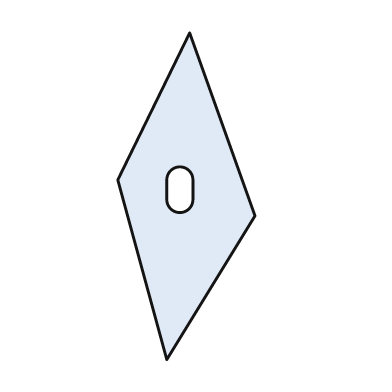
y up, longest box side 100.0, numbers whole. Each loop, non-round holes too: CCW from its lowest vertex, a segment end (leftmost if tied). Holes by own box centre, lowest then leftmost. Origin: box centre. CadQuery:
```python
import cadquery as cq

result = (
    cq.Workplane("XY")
    .moveTo(-6.0, -50.0)
    .lineTo(21.0, -6.0)
    .lineTo(1.0, 50.0)
    .lineTo(-21.0, 5.0)
    .close()
    .moveTo(-6.0, -1.0)
    .threePointArc((-2.0, -5.0), (2.0, -1.0))
    .lineTo(2.0, 5.0)
    .threePointArc((-2.0, 9.0), (-6.0, 5.0))
    .close()
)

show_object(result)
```